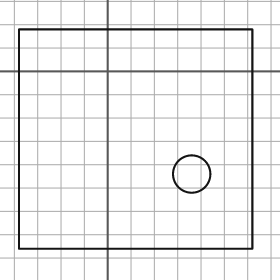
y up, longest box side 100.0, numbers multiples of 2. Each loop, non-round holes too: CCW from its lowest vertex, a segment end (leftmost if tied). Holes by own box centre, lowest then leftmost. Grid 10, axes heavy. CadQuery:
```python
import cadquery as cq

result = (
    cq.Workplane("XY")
    .moveTo(-38.0, -76.0)
    .lineTo(62.0, -76.0)
    .lineTo(62.0, 18.0)
    .lineTo(-38.0, 18.0)
    .close()
    .moveTo(36.0, -44.0)
    .circle(8.0)
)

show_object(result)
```